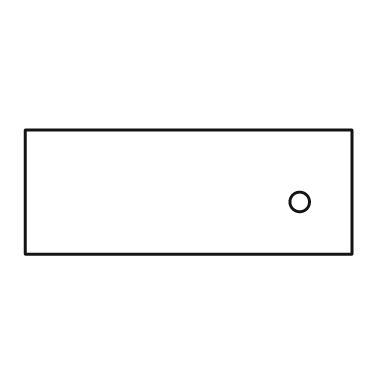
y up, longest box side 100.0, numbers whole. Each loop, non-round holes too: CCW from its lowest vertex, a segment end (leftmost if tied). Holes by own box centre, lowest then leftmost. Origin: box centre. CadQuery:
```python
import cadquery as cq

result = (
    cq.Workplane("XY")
    .moveTo(-50.0, -19.0)
    .lineTo(50.0, -19.0)
    .lineTo(50.0, 19.0)
    .lineTo(-50.0, 19.0)
    .close()
    .moveTo(34.0, -3.0)
    .circle(3.0)
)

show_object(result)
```